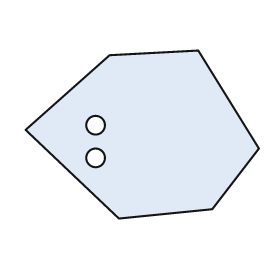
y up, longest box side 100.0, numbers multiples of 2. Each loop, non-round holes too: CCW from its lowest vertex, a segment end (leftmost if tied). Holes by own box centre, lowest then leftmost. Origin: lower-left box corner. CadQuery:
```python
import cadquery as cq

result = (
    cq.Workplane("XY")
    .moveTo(40.0, 0.0)
    .lineTo(80.0, 4.0)
    .lineTo(100.0, 30.0)
    .lineTo(74.0, 72.0)
    .lineTo(36.0, 70.0)
    .lineTo(0.0, 38.0)
    .close()
    .moveTo(30.0, 26.0)
    .circle(4.0)
    .moveTo(30.0, 40.0)
    .circle(4.0)
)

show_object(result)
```